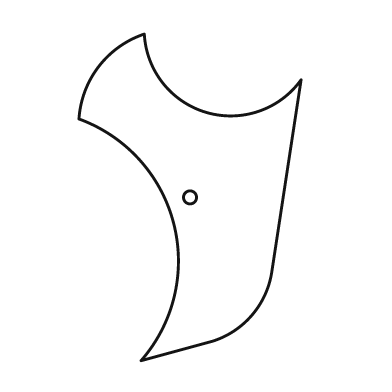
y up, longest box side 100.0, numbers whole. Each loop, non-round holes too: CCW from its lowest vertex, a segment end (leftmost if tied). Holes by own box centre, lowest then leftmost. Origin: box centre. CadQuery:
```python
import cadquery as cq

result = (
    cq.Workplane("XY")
    .moveTo(-15.0, -50.0)
    .lineTo(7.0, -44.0)
    .threePointArc((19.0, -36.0), (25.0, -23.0))
    .lineTo(34.0, 36.0)
    .threePointArc((5.0, 26.0), (-14.0, 50.0))
    .threePointArc((-28.0, 40.0), (-34.0, 24.0))
    .threePointArc((-5.0, -8.0), (-15.0, -50.0))
    .close()
    .moveTo(0.0, 0.0)
    .circle(2.0)
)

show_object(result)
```